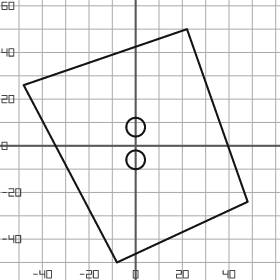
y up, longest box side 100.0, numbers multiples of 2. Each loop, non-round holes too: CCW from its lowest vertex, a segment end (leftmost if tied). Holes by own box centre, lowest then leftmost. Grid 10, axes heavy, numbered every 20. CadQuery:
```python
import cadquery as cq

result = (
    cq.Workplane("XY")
    .moveTo(-8.0, -50.0)
    .lineTo(48.0, -24.0)
    .lineTo(22.0, 50.0)
    .lineTo(-48.0, 26.0)
    .close()
    .moveTo(0.0, -6.0)
    .circle(4.0)
    .moveTo(0.0, 8.0)
    .circle(4.0)
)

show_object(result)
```